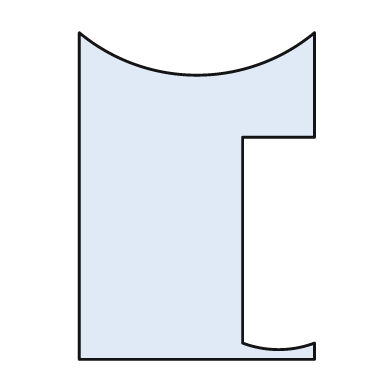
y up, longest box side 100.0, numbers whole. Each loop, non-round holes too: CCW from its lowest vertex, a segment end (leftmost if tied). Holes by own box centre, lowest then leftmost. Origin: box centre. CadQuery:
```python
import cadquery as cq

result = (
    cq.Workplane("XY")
    .moveTo(-36.0, -50.0)
    .lineTo(36.0, -50.0)
    .lineTo(36.0, -45.0)
    .threePointArc((25.0, -47.0), (14.0, -45.0))
    .lineTo(14.0, 18.0)
    .lineTo(36.0, 18.0)
    .lineTo(36.0, 50.0)
    .threePointArc((0.0, 37.0), (-36.0, 50.0))
    .close()
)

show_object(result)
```